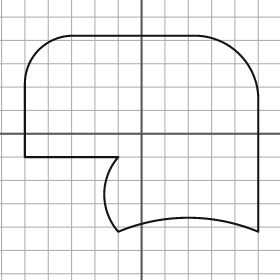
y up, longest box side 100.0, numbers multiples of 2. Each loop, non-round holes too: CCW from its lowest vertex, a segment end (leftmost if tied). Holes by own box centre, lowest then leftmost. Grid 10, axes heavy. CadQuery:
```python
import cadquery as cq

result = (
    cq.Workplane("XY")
    .moveTo(-10.0, -42.0)
    .threePointArc((20.0, -36.0), (50.0, -42.0))
    .lineTo(50.0, 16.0)
    .threePointArc((42.0, 34.0), (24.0, 42.0))
    .lineTo(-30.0, 42.0)
    .threePointArc((-44.0, 36.0), (-50.0, 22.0))
    .lineTo(-50.0, -10.0)
    .lineTo(-10.0, -10.0)
    .threePointArc((-16.0, -26.0), (-10.0, -42.0))
    .close()
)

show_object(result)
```